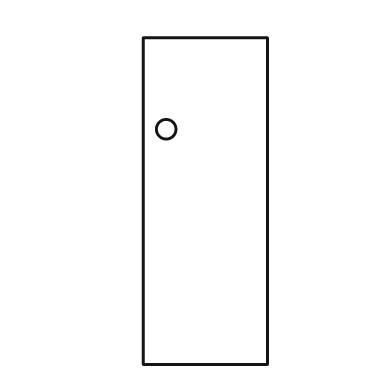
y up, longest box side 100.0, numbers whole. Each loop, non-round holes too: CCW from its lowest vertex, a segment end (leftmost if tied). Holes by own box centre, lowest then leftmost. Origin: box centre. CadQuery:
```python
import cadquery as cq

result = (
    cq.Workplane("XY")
    .moveTo(-19.0, -50.0)
    .lineTo(19.0, -50.0)
    .lineTo(19.0, 50.0)
    .lineTo(-19.0, 50.0)
    .close()
    .moveTo(-12.0, 22.0)
    .circle(3.0)
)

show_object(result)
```